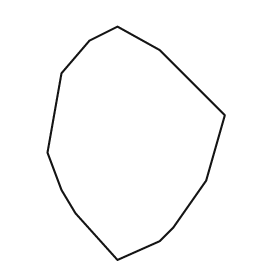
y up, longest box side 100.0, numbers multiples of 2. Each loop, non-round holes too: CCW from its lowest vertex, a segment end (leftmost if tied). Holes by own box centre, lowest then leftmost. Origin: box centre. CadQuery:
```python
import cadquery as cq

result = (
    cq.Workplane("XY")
    .moveTo(-8.0, -50.0)
    .lineTo(10.0, -42.0)
    .lineTo(16.0, -36.0)
    .lineTo(30.0, -16.0)
    .lineTo(38.0, 12.0)
    .lineTo(10.0, 40.0)
    .lineTo(-8.0, 50.0)
    .lineTo(-20.0, 44.0)
    .lineTo(-32.0, 30.0)
    .lineTo(-38.0, -4.0)
    .lineTo(-32.0, -20.0)
    .lineTo(-26.0, -30.0)
    .close()
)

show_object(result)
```